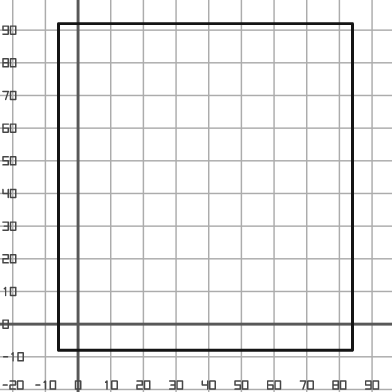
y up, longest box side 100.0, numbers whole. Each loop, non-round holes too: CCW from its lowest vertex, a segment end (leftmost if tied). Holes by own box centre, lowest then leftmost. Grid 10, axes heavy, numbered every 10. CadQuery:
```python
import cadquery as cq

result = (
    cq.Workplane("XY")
    .moveTo(-6.0, -8.0)
    .lineTo(84.0, -8.0)
    .lineTo(84.0, 92.0)
    .lineTo(-6.0, 92.0)
    .close()
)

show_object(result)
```